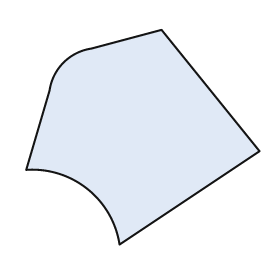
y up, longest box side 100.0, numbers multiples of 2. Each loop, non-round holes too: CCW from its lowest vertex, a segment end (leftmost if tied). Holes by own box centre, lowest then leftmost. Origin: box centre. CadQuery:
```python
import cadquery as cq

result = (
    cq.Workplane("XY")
    .moveTo(-10.0, -46.0)
    .lineTo(50.0, -6.0)
    .lineTo(8.0, 46.0)
    .lineTo(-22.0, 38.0)
    .threePointArc((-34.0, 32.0), (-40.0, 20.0))
    .lineTo(-50.0, -14.0)
    .threePointArc((-24.0, -22.0), (-10.0, -46.0))
    .close()
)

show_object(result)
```